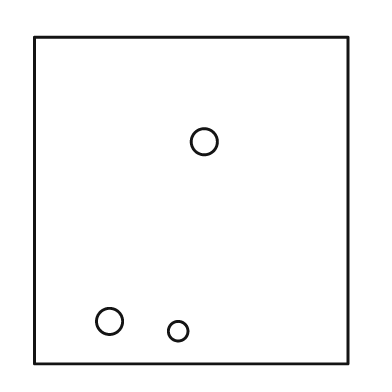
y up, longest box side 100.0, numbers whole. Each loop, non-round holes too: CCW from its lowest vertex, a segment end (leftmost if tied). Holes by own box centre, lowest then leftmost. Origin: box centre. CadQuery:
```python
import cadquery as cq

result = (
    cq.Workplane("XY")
    .moveTo(-48.0, -50.0)
    .lineTo(48.0, -50.0)
    .lineTo(48.0, 50.0)
    .lineTo(-48.0, 50.0)
    .close()
    .moveTo(-4.0, -40.0)
    .circle(3.0)
    .moveTo(-25.0, -37.0)
    .circle(4.0)
    .moveTo(4.0, 18.0)
    .circle(4.0)
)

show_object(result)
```